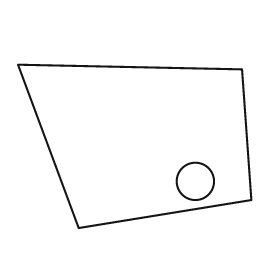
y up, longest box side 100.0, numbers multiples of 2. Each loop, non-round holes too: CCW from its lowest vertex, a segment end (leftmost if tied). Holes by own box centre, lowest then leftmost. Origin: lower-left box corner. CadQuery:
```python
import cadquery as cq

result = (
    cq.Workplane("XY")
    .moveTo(26.0, 0.0)
    .lineTo(100.0, 12.0)
    .lineTo(96.0, 68.0)
    .lineTo(0.0, 70.0)
    .close()
    .moveTo(76.0, 20.0)
    .circle(8.0)
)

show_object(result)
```